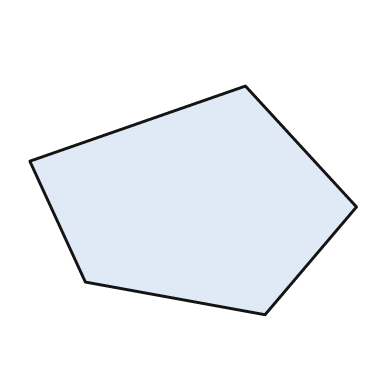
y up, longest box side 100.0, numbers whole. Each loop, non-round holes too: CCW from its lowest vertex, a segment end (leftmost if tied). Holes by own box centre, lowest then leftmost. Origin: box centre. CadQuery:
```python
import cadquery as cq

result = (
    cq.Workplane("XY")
    .moveTo(22.0, -35.0)
    .lineTo(50.0, -2.0)
    .lineTo(16.0, 35.0)
    .lineTo(-50.0, 12.0)
    .lineTo(-33.0, -25.0)
    .close()
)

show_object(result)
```